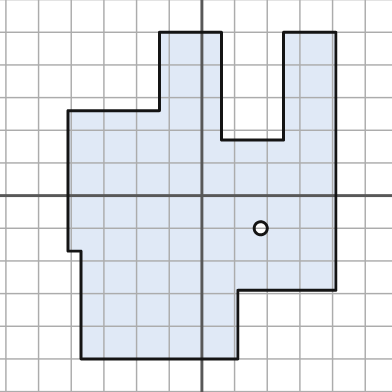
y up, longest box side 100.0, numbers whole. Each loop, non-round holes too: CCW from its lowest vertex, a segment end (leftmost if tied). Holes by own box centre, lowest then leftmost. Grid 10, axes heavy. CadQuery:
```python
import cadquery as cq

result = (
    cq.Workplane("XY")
    .moveTo(-37.0, -50.0)
    .lineTo(11.0, -50.0)
    .lineTo(11.0, -29.0)
    .lineTo(41.0, -29.0)
    .lineTo(41.0, 50.0)
    .lineTo(25.0, 50.0)
    .lineTo(25.0, 17.0)
    .lineTo(6.0, 17.0)
    .lineTo(6.0, 50.0)
    .lineTo(-13.0, 50.0)
    .lineTo(-13.0, 26.0)
    .lineTo(-41.0, 26.0)
    .lineTo(-41.0, -17.0)
    .lineTo(-37.0, -17.0)
    .close()
    .moveTo(18.0, -10.0)
    .circle(2.0)
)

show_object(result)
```